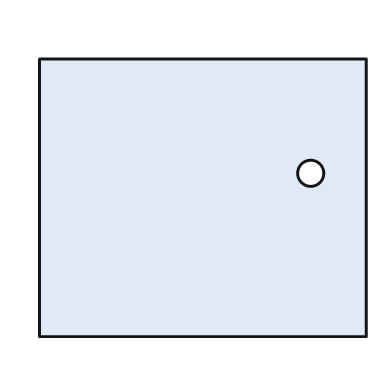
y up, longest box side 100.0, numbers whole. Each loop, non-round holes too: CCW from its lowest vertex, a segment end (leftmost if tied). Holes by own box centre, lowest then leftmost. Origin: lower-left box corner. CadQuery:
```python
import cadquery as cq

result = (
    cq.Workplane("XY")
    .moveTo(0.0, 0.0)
    .lineTo(100.0, 0.0)
    .lineTo(100.0, 85.0)
    .lineTo(0.0, 85.0)
    .close()
    .moveTo(83.0, 50.0)
    .circle(4.0)
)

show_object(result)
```